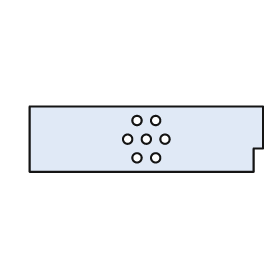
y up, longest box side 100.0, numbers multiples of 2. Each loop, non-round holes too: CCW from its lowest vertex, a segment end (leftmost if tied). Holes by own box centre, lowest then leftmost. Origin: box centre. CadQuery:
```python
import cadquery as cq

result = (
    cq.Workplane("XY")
    .moveTo(-50.0, -14.0)
    .lineTo(46.0, -14.0)
    .lineTo(46.0, -4.0)
    .lineTo(50.0, -4.0)
    .lineTo(50.0, 14.0)
    .lineTo(-50.0, 14.0)
    .close()
    .moveTo(-4.0, -8.0)
    .circle(2.0)
    .moveTo(4.0, -8.0)
    .circle(2.0)
    .moveTo(-8.0, 0.0)
    .circle(2.0)
    .moveTo(0.0, 0.0)
    .circle(2.0)
    .moveTo(8.0, 0.0)
    .circle(2.0)
    .moveTo(-4.0, 8.0)
    .circle(2.0)
    .moveTo(4.0, 8.0)
    .circle(2.0)
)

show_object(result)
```